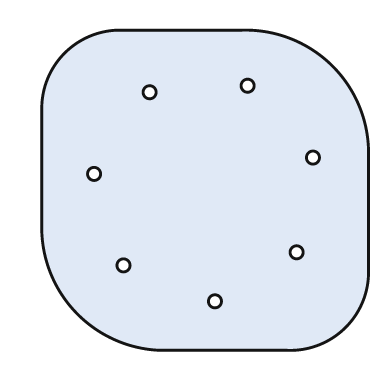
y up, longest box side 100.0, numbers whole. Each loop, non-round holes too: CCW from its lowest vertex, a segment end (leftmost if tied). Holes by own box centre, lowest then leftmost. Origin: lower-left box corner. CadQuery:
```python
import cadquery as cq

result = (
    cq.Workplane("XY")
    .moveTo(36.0, 0.0)
    .lineTo(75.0, 0.0)
    .threePointArc((93.0, 7.0), (100.0, 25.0))
    .lineTo(100.0, 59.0)
    .threePointArc((89.0, 87.0), (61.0, 98.0))
    .lineTo(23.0, 98.0)
    .threePointArc((7.0, 91.0), (0.0, 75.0))
    .lineTo(0.0, 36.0)
    .threePointArc((11.0, 11.0), (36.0, 0.0))
    .close()
    .moveTo(53.0, 15.0)
    .circle(2.0)
    .moveTo(25.0, 26.0)
    .circle(2.0)
    .moveTo(78.0, 30.0)
    .circle(2.0)
    .moveTo(16.0, 54.0)
    .circle(2.0)
    .moveTo(83.0, 59.0)
    .circle(2.0)
    .moveTo(33.0, 79.0)
    .circle(2.0)
    .moveTo(63.0, 81.0)
    .circle(2.0)
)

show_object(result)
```